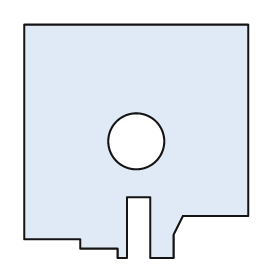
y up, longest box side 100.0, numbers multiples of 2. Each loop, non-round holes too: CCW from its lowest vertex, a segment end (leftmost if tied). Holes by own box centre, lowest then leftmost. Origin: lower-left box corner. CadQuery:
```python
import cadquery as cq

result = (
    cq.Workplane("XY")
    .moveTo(40.0, 0.0)
    .lineTo(44.0, 0.0)
    .lineTo(44.0, 26.0)
    .lineTo(54.0, 26.0)
    .lineTo(54.0, 0.0)
    .lineTo(64.0, 0.0)
    .lineTo(64.0, 10.0)
    .lineTo(68.0, 18.0)
    .lineTo(96.0, 18.0)
    .lineTo(96.0, 100.0)
    .lineTo(0.0, 100.0)
    .lineTo(0.0, 8.0)
    .lineTo(24.0, 8.0)
    .lineTo(24.0, 4.0)
    .lineTo(40.0, 4.0)
    .close()
    .moveTo(48.0, 50.0)
    .circle(12.0)
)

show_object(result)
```